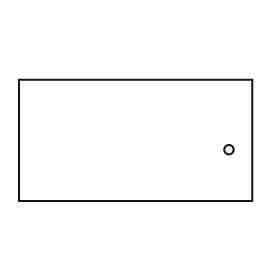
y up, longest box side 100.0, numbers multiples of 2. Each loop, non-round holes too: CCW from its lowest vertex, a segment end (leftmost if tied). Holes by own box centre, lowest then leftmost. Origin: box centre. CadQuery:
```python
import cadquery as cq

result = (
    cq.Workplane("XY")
    .moveTo(-50.0, -26.0)
    .lineTo(50.0, -26.0)
    .lineTo(50.0, 26.0)
    .lineTo(-50.0, 26.0)
    .close()
    .moveTo(40.0, -4.0)
    .circle(2.0)
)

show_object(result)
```